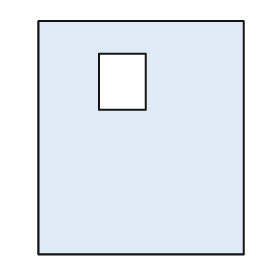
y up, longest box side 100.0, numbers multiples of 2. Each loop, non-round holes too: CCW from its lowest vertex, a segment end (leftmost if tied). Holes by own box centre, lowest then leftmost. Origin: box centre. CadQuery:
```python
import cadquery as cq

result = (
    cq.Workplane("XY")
    .moveTo(-44.0, -50.0)
    .lineTo(44.0, -50.0)
    .lineTo(44.0, 50.0)
    .lineTo(-44.0, 50.0)
    .close()
    .moveTo(-18.0, 12.0)
    .lineTo(2.0, 12.0)
    .lineTo(2.0, 36.0)
    .lineTo(-18.0, 36.0)
    .close()
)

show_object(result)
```